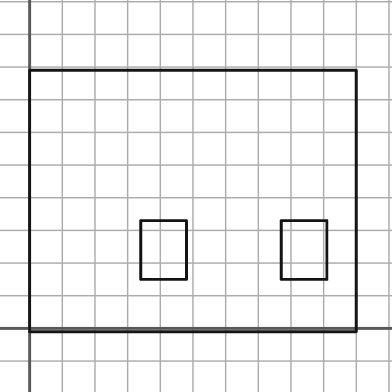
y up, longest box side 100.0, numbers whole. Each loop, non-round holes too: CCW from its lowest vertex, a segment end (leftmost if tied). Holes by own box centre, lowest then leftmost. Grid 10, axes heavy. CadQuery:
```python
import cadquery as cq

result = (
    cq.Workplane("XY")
    .moveTo(0.0, -1.0)
    .lineTo(100.0, -1.0)
    .lineTo(100.0, 79.0)
    .lineTo(0.0, 79.0)
    .close()
    .moveTo(34.0, 15.0)
    .lineTo(48.0, 15.0)
    .lineTo(48.0, 33.0)
    .lineTo(34.0, 33.0)
    .close()
    .moveTo(77.0, 15.0)
    .lineTo(91.0, 15.0)
    .lineTo(91.0, 33.0)
    .lineTo(77.0, 33.0)
    .close()
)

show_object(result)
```